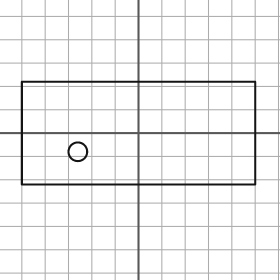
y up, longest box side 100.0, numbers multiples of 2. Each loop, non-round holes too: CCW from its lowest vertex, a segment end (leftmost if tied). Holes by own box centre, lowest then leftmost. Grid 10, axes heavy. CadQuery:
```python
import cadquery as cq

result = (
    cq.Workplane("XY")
    .moveTo(-50.0, -22.0)
    .lineTo(50.0, -22.0)
    .lineTo(50.0, 22.0)
    .lineTo(-50.0, 22.0)
    .close()
    .moveTo(-26.0, -8.0)
    .circle(4.0)
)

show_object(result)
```